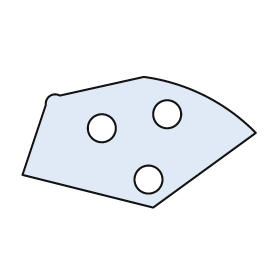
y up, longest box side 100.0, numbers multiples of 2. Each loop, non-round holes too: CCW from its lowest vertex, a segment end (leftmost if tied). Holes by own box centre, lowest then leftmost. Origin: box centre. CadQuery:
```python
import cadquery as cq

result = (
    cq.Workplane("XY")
    .moveTo(6.0, -28.0)
    .lineTo(50.0, 4.0)
    .threePointArc((28.0, 20.0), (2.0, 28.0))
    .lineTo(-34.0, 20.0)
    .threePointArc((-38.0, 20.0), (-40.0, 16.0))
    .lineTo(-50.0, -14.0)
    .close()
    .moveTo(4.0, -16.0)
    .circle(6.0)
    .moveTo(-16.0, 6.0)
    .circle(6.0)
    .moveTo(12.0, 12.0)
    .circle(6.0)
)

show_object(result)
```